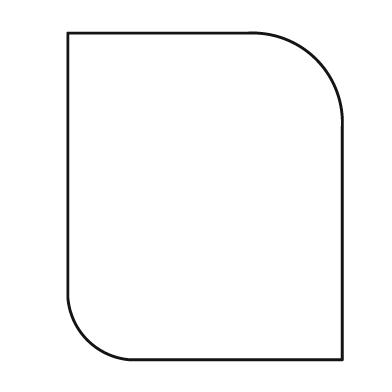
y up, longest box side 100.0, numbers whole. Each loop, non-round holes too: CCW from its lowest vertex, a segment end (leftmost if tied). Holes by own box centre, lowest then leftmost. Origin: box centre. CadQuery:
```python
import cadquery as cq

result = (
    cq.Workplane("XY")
    .moveTo(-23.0, -50.0)
    .lineTo(42.0, -50.0)
    .lineTo(42.0, 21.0)
    .threePointArc((34.0, 42.0), (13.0, 50.0))
    .lineTo(-42.0, 50.0)
    .lineTo(-42.0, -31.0)
    .threePointArc((-36.0, -44.0), (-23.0, -50.0))
    .close()
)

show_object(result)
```